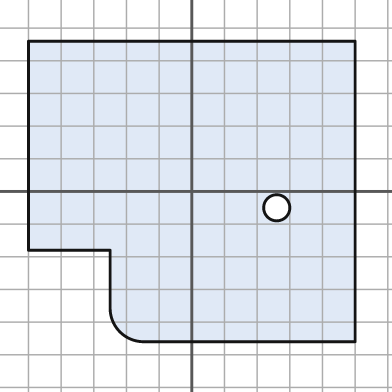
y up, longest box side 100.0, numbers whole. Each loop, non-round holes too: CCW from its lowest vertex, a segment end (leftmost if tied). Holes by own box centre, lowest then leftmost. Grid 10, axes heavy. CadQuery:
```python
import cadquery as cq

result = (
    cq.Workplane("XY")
    .moveTo(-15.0, -46.0)
    .lineTo(50.0, -46.0)
    .lineTo(50.0, 46.0)
    .lineTo(-50.0, 46.0)
    .lineTo(-50.0, -18.0)
    .lineTo(-25.0, -18.0)
    .lineTo(-25.0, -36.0)
    .threePointArc((-22.0, -43.0), (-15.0, -46.0))
    .close()
    .moveTo(26.0, -5.0)
    .circle(4.0)
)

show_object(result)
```